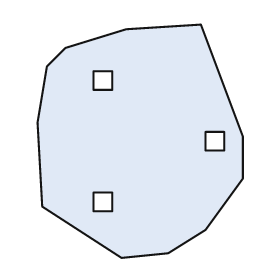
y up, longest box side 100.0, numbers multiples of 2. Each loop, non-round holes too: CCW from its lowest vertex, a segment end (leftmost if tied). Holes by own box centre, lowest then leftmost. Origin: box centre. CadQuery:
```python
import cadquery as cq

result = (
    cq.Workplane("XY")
    .moveTo(-8.0, -50.0)
    .lineTo(12.0, -48.0)
    .lineTo(28.0, -38.0)
    .lineTo(44.0, -16.0)
    .lineTo(44.0, 2.0)
    .lineTo(26.0, 50.0)
    .lineTo(-6.0, 48.0)
    .lineTo(-32.0, 40.0)
    .lineTo(-40.0, 32.0)
    .lineTo(-44.0, 8.0)
    .lineTo(-42.0, -28.0)
    .close()
    .moveTo(-20.0, -30.0)
    .lineTo(-12.0, -30.0)
    .lineTo(-12.0, -22.0)
    .lineTo(-20.0, -22.0)
    .close()
    .moveTo(28.0, -4.0)
    .lineTo(36.0, -4.0)
    .lineTo(36.0, 4.0)
    .lineTo(28.0, 4.0)
    .close()
    .moveTo(-20.0, 22.0)
    .lineTo(-12.0, 22.0)
    .lineTo(-12.0, 30.0)
    .lineTo(-20.0, 30.0)
    .close()
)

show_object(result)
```